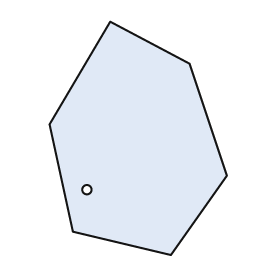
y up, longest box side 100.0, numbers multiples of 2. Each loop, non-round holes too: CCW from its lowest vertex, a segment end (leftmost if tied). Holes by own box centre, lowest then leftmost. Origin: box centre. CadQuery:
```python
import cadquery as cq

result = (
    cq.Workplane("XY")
    .moveTo(14.0, -50.0)
    .lineTo(38.0, -16.0)
    .lineTo(22.0, 32.0)
    .lineTo(-12.0, 50.0)
    .lineTo(-38.0, 6.0)
    .lineTo(-28.0, -40.0)
    .close()
    .moveTo(-22.0, -22.0)
    .circle(2.0)
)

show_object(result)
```